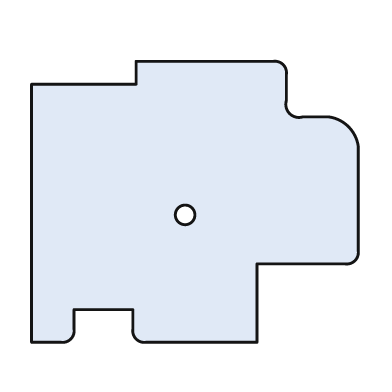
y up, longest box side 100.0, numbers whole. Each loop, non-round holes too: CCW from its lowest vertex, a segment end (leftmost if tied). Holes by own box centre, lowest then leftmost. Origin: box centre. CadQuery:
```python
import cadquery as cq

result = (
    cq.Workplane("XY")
    .moveTo(-50.0, -43.0)
    .lineTo(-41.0, -43.0)
    .threePointArc((-38.0, -42.0), (-37.0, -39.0))
    .lineTo(-37.0, -33.0)
    .lineTo(-19.0, -33.0)
    .lineTo(-19.0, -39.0)
    .threePointArc((-18.0, -42.0), (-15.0, -43.0))
    .lineTo(19.0, -43.0)
    .lineTo(19.0, -19.0)
    .lineTo(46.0, -19.0)
    .threePointArc((49.0, -18.0), (50.0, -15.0))
    .lineTo(50.0, 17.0)
    .threePointArc((47.0, 23.0), (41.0, 26.0))
    .lineTo(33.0, 26.0)
    .threePointArc((29.0, 27.0), (28.0, 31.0))
    .lineTo(28.0, 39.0)
    .threePointArc((27.0, 42.0), (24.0, 43.0))
    .lineTo(-18.0, 43.0)
    .lineTo(-18.0, 36.0)
    .lineTo(-50.0, 36.0)
    .close()
    .moveTo(-3.0, -4.0)
    .circle(3.0)
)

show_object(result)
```